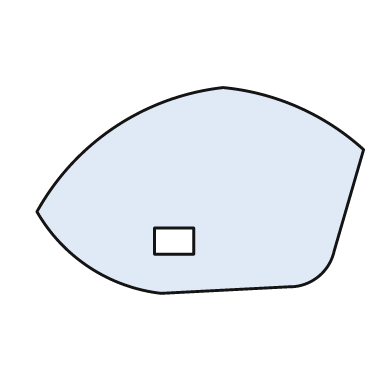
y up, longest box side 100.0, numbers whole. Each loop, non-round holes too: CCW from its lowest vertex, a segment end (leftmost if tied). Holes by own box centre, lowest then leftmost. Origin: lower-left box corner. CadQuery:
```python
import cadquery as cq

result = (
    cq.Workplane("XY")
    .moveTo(38.0, 0.0)
    .lineTo(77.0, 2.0)
    .threePointArc((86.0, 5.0), (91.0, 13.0))
    .lineTo(100.0, 44.0)
    .threePointArc((80.0, 57.0), (57.0, 63.0))
    .threePointArc((24.0, 51.0), (0.0, 25.0))
    .threePointArc((16.0, 8.0), (38.0, 0.0))
    .close()
    .moveTo(36.0, 12.0)
    .lineTo(48.0, 12.0)
    .lineTo(48.0, 20.0)
    .lineTo(36.0, 20.0)
    .close()
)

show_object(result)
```